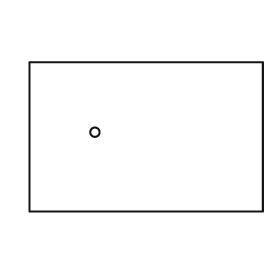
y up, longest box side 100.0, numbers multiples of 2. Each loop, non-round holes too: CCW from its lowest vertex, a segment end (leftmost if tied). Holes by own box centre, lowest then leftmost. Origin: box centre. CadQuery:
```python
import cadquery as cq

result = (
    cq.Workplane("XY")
    .moveTo(-50.0, -32.0)
    .lineTo(50.0, -32.0)
    .lineTo(50.0, 32.0)
    .lineTo(-50.0, 32.0)
    .close()
    .moveTo(-22.0, 2.0)
    .circle(2.0)
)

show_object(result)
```